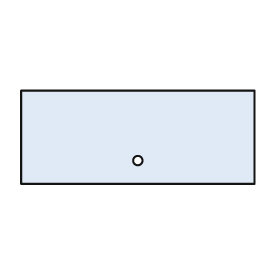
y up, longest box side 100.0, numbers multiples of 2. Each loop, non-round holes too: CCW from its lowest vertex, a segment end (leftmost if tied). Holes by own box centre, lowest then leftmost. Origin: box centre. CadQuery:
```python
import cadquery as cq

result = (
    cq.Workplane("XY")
    .moveTo(-50.0, -20.0)
    .lineTo(50.0, -20.0)
    .lineTo(50.0, 20.0)
    .lineTo(-50.0, 20.0)
    .close()
    .moveTo(0.0, -10.0)
    .circle(2.0)
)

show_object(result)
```